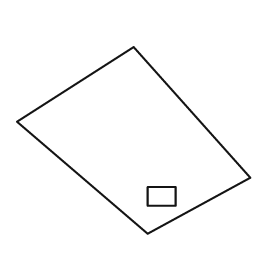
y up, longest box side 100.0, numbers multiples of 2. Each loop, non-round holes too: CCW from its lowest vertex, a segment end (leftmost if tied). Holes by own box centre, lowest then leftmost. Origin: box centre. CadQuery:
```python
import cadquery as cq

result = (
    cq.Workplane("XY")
    .moveTo(6.0, -40.0)
    .lineTo(50.0, -16.0)
    .lineTo(0.0, 40.0)
    .lineTo(-50.0, 8.0)
    .close()
    .moveTo(6.0, -28.0)
    .lineTo(18.0, -28.0)
    .lineTo(18.0, -20.0)
    .lineTo(6.0, -20.0)
    .close()
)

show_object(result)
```